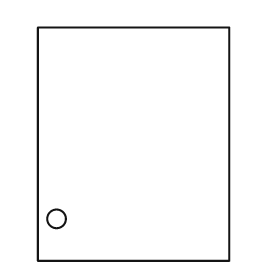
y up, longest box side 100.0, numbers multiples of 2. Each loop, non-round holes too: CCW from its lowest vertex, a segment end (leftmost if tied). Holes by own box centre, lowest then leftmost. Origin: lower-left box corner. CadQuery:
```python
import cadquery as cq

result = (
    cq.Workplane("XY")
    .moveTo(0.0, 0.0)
    .lineTo(82.0, 0.0)
    .lineTo(82.0, 100.0)
    .lineTo(0.0, 100.0)
    .close()
    .moveTo(8.0, 18.0)
    .circle(4.0)
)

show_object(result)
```